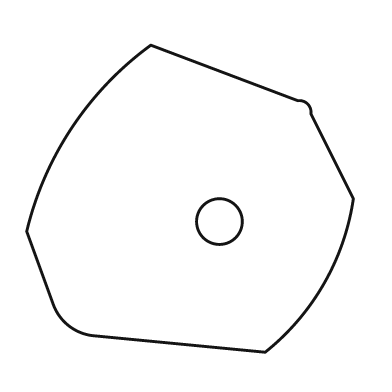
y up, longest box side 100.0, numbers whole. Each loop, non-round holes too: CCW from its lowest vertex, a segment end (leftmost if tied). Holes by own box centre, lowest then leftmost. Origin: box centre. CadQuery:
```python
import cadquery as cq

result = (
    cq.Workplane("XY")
    .moveTo(23.0, -47.0)
    .threePointArc((41.0, -26.0), (50.0, 0.0))
    .lineTo(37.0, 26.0)
    .threePointArc((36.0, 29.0), (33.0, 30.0))
    .lineTo(-12.0, 47.0)
    .threePointArc((-36.0, 22.0), (-50.0, -10.0))
    .lineTo(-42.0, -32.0)
    .threePointArc((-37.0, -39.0), (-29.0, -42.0))
    .close()
    .moveTo(9.0, -7.0)
    .circle(7.0)
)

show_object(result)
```